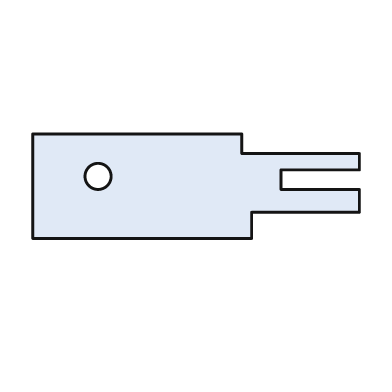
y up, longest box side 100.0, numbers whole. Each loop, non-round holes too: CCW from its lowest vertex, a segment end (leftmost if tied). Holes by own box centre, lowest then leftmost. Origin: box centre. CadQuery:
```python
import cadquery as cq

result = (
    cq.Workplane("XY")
    .moveTo(-50.0, -16.0)
    .lineTo(17.0, -16.0)
    .lineTo(17.0, -8.0)
    .lineTo(50.0, -8.0)
    .lineTo(50.0, -1.0)
    .lineTo(26.0, -1.0)
    .lineTo(26.0, 5.0)
    .lineTo(50.0, 5.0)
    .lineTo(50.0, 10.0)
    .lineTo(14.0, 10.0)
    .lineTo(14.0, 16.0)
    .lineTo(-50.0, 16.0)
    .close()
    .moveTo(-30.0, 3.0)
    .circle(4.0)
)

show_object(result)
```